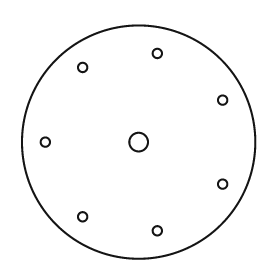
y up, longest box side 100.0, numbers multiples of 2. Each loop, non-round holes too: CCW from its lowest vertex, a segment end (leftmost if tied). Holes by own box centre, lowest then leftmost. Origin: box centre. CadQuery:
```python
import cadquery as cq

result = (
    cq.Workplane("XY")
    .moveTo(0.0, 0.0)
    .circle(50.0)
    .moveTo(8.0, -38.0)
    .circle(2.0)
    .moveTo(-24.0, -32.0)
    .circle(2.0)
    .moveTo(36.0, -18.0)
    .circle(2.0)
    .moveTo(-40.0, 0.0)
    .circle(2.0)
    .moveTo(0.0, 0.0)
    .circle(4.0)
    .moveTo(36.0, 18.0)
    .circle(2.0)
    .moveTo(-24.0, 32.0)
    .circle(2.0)
    .moveTo(8.0, 38.0)
    .circle(2.0)
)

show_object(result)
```